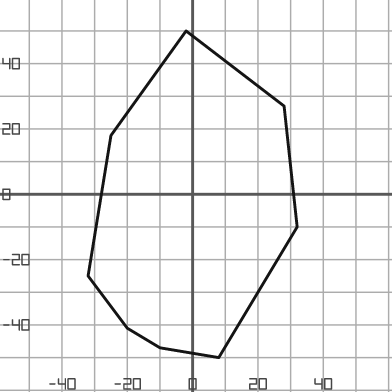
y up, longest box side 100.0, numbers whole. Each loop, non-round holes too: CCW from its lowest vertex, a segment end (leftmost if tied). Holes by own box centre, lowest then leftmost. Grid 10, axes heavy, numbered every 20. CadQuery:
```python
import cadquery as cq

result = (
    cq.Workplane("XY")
    .moveTo(8.0, -50.0)
    .lineTo(32.0, -10.0)
    .lineTo(28.0, 27.0)
    .lineTo(-2.0, 50.0)
    .lineTo(-25.0, 18.0)
    .lineTo(-32.0, -25.0)
    .lineTo(-20.0, -41.0)
    .lineTo(-10.0, -47.0)
    .close()
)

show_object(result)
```